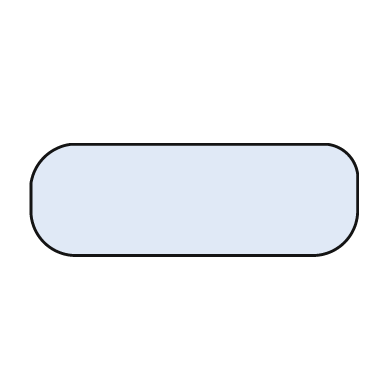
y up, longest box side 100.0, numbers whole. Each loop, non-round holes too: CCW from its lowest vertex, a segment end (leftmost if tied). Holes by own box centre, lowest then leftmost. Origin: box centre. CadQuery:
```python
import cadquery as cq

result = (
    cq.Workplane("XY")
    .moveTo(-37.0, -17.0)
    .lineTo(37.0, -17.0)
    .threePointArc((46.0, -13.0), (50.0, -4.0))
    .lineTo(50.0, 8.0)
    .threePointArc((47.0, 14.0), (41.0, 17.0))
    .lineTo(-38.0, 17.0)
    .threePointArc((-46.0, 13.0), (-50.0, 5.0))
    .lineTo(-50.0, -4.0)
    .threePointArc((-46.0, -13.0), (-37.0, -17.0))
    .close()
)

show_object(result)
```